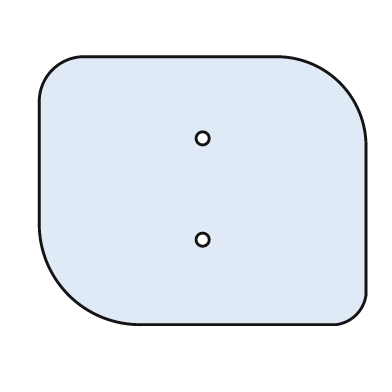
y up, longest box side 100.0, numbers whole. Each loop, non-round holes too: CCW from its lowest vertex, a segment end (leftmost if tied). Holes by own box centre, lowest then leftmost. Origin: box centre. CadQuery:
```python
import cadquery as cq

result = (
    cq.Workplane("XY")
    .moveTo(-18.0, -41.0)
    .lineTo(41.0, -41.0)
    .threePointArc((47.0, -38.0), (50.0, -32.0))
    .lineTo(50.0, 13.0)
    .threePointArc((42.0, 33.0), (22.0, 41.0))
    .lineTo(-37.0, 41.0)
    .threePointArc((-46.0, 37.0), (-50.0, 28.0))
    .lineTo(-50.0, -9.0)
    .threePointArc((-41.0, -32.0), (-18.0, -41.0))
    .close()
    .moveTo(0.0, -15.0)
    .circle(2.0)
    .moveTo(0.0, 16.0)
    .circle(2.0)
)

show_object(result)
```